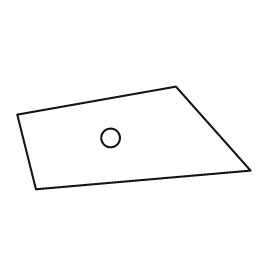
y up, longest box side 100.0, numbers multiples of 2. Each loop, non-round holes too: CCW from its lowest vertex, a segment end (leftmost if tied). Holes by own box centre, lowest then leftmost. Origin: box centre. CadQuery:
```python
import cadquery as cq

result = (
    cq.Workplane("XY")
    .moveTo(-42.0, -22.0)
    .lineTo(50.0, -14.0)
    .lineTo(18.0, 22.0)
    .lineTo(-50.0, 10.0)
    .close()
    .moveTo(-10.0, 0.0)
    .circle(4.0)
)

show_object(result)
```